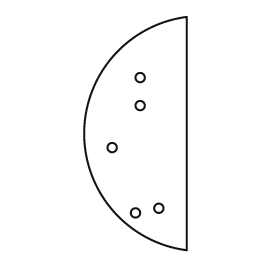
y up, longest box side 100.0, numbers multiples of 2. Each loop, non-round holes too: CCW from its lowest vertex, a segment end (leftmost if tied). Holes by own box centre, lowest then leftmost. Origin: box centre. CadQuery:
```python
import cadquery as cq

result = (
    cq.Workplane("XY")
    .moveTo(22.0, -50.0)
    .lineTo(22.0, 50.0)
    .threePointArc((-22.0, 0.0), (22.0, -50.0))
    .close()
    .moveTo(0.0, -34.0)
    .circle(2.0)
    .moveTo(10.0, -32.0)
    .circle(2.0)
    .moveTo(-10.0, -6.0)
    .circle(2.0)
    .moveTo(2.0, 12.0)
    .circle(2.0)
    .moveTo(2.0, 24.0)
    .circle(2.0)
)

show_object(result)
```